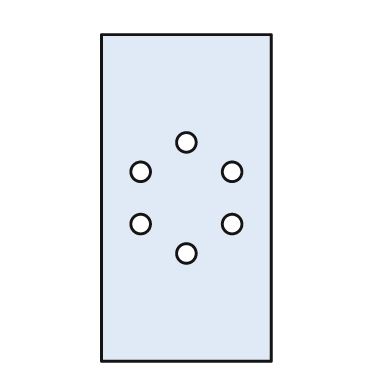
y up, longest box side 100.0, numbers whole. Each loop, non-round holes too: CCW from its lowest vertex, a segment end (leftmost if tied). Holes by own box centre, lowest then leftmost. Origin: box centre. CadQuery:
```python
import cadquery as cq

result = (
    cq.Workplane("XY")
    .moveTo(-26.0, -50.0)
    .lineTo(26.0, -50.0)
    .lineTo(26.0, 50.0)
    .lineTo(-26.0, 50.0)
    .close()
    .moveTo(0.0, -17.0)
    .circle(3.0)
    .moveTo(-14.0, -8.0)
    .circle(3.0)
    .moveTo(14.0, -8.0)
    .circle(3.0)
    .moveTo(-14.0, 8.0)
    .circle(3.0)
    .moveTo(14.0, 8.0)
    .circle(3.0)
    .moveTo(0.0, 17.0)
    .circle(3.0)
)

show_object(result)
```